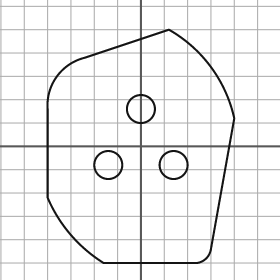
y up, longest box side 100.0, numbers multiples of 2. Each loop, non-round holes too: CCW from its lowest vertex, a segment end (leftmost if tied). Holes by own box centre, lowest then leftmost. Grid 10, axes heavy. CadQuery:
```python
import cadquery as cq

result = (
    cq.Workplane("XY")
    .moveTo(-16.0, -50.0)
    .lineTo(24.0, -50.0)
    .threePointArc((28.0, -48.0), (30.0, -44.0))
    .lineTo(40.0, 12.0)
    .threePointArc((30.0, 34.0), (12.0, 50.0))
    .lineTo(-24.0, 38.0)
    .threePointArc((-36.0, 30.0), (-40.0, 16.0))
    .lineTo(-40.0, -22.0)
    .threePointArc((-30.0, -38.0), (-16.0, -50.0))
    .close()
    .moveTo(-14.0, -8.0)
    .circle(6.0)
    .moveTo(14.0, -8.0)
    .circle(6.0)
    .moveTo(0.0, 16.0)
    .circle(6.0)
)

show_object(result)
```